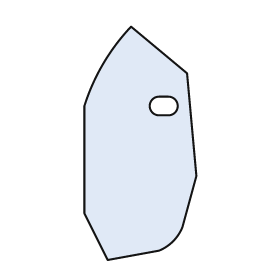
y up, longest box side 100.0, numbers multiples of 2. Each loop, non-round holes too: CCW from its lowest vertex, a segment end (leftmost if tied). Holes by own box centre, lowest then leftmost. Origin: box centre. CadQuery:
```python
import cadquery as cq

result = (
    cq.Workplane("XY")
    .moveTo(-14.0, -50.0)
    .lineTo(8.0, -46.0)
    .threePointArc((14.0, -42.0), (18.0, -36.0))
    .lineTo(24.0, -14.0)
    .lineTo(20.0, 30.0)
    .lineTo(-4.0, 50.0)
    .threePointArc((-16.0, 34.0), (-24.0, 16.0))
    .lineTo(-24.0, -30.0)
    .close()
    .moveTo(8.0, 12.0)
    .lineTo(12.0, 12.0)
    .threePointArc((16.0, 16.0), (12.0, 20.0))
    .lineTo(8.0, 20.0)
    .threePointArc((4.0, 16.0), (8.0, 12.0))
    .close()
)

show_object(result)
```